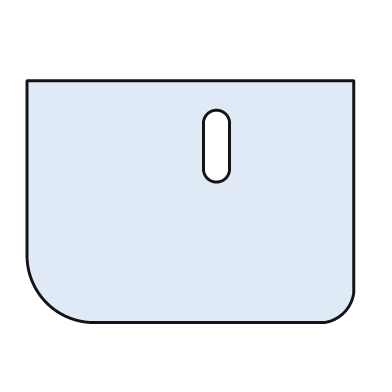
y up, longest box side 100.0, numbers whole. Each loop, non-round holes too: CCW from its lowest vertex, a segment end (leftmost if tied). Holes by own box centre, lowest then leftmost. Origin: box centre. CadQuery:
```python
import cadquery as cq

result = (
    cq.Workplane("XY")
    .moveTo(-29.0, -37.0)
    .lineTo(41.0, -37.0)
    .threePointArc((47.0, -34.0), (50.0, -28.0))
    .lineTo(50.0, 37.0)
    .lineTo(-50.0, 37.0)
    .lineTo(-50.0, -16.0)
    .threePointArc((-44.0, -31.0), (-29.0, -37.0))
    .close()
    .moveTo(4.0, 10.0)
    .threePointArc((8.0, 6.0), (12.0, 10.0))
    .lineTo(12.0, 24.0)
    .threePointArc((8.0, 28.0), (4.0, 24.0))
    .close()
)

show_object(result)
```